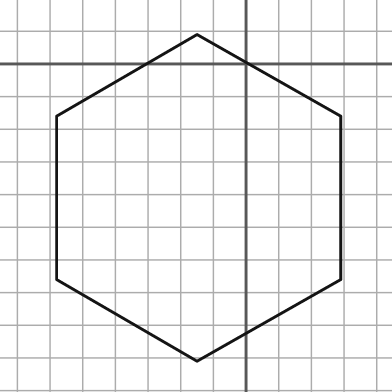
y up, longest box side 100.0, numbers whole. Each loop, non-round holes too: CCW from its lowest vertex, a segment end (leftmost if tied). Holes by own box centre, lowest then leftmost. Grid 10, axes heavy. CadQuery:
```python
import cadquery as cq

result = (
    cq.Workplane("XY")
    .moveTo(-15.0, -91.0)
    .lineTo(29.0, -66.0)
    .lineTo(29.0, -16.0)
    .lineTo(-15.0, 9.0)
    .lineTo(-58.0, -16.0)
    .lineTo(-58.0, -66.0)
    .close()
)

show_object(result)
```